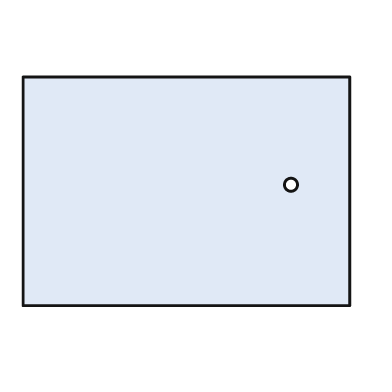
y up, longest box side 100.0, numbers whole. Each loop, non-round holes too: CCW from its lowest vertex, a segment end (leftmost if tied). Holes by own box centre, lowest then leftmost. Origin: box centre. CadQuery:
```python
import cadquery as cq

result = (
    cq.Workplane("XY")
    .moveTo(-50.0, -35.0)
    .lineTo(50.0, -35.0)
    .lineTo(50.0, 35.0)
    .lineTo(-50.0, 35.0)
    .close()
    .moveTo(32.0, 2.0)
    .circle(2.0)
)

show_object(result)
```